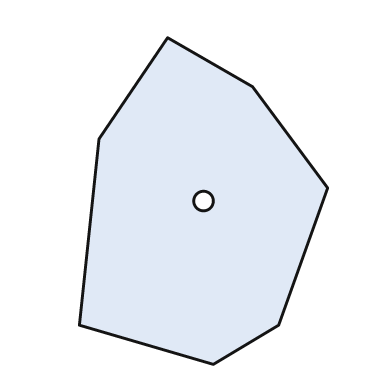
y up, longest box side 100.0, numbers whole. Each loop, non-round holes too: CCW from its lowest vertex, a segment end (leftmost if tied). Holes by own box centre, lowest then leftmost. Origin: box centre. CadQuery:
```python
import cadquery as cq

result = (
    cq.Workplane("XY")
    .moveTo(3.0, -50.0)
    .lineTo(23.0, -38.0)
    .lineTo(38.0, 4.0)
    .lineTo(15.0, 35.0)
    .lineTo(-11.0, 50.0)
    .lineTo(-32.0, 19.0)
    .lineTo(-38.0, -38.0)
    .close()
    .moveTo(0.0, 0.0)
    .circle(3.0)
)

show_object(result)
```